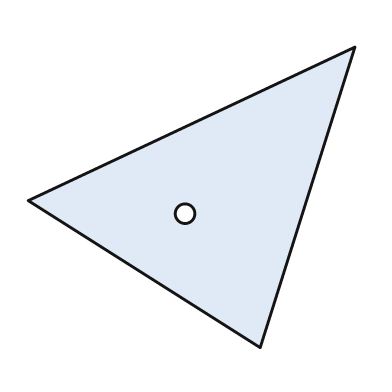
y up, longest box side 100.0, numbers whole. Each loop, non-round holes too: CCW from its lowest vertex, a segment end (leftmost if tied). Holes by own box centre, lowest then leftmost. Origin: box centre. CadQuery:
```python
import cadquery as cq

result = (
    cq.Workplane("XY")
    .moveTo(21.0, -46.0)
    .lineTo(50.0, 46.0)
    .lineTo(-50.0, -1.0)
    .close()
    .moveTo(-2.0, -5.0)
    .circle(3.0)
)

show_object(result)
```